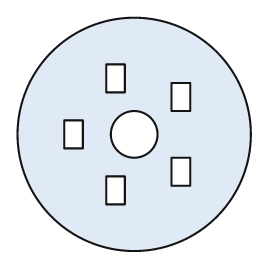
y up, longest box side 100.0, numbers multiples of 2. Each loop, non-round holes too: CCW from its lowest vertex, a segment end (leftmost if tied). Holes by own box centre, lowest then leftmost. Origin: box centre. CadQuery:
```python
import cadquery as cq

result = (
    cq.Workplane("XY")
    .moveTo(0.0, 0.0)
    .circle(50.0)
    .moveTo(-12.0, -30.0)
    .lineTo(-4.0, -30.0)
    .lineTo(-4.0, -18.0)
    .lineTo(-12.0, -18.0)
    .close()
    .moveTo(16.0, -22.0)
    .lineTo(24.0, -22.0)
    .lineTo(24.0, -10.0)
    .lineTo(16.0, -10.0)
    .close()
    .moveTo(-30.0, -6.0)
    .lineTo(-22.0, -6.0)
    .lineTo(-22.0, 6.0)
    .lineTo(-30.0, 6.0)
    .close()
    .moveTo(0.0, 0.0)
    .circle(10.0)
    .moveTo(16.0, 10.0)
    .lineTo(24.0, 10.0)
    .lineTo(24.0, 22.0)
    .lineTo(16.0, 22.0)
    .close()
    .moveTo(-12.0, 18.0)
    .lineTo(-4.0, 18.0)
    .lineTo(-4.0, 30.0)
    .lineTo(-12.0, 30.0)
    .close()
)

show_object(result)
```